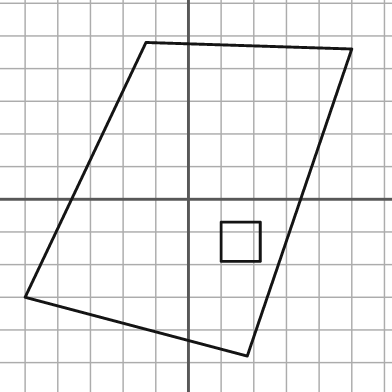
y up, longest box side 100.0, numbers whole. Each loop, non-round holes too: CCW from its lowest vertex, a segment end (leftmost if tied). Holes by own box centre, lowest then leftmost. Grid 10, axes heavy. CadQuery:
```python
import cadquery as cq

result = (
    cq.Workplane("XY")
    .moveTo(18.0, -48.0)
    .lineTo(50.0, 46.0)
    .lineTo(-13.0, 48.0)
    .lineTo(-50.0, -30.0)
    .close()
    .moveTo(10.0, -19.0)
    .lineTo(22.0, -19.0)
    .lineTo(22.0, -7.0)
    .lineTo(10.0, -7.0)
    .close()
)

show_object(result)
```